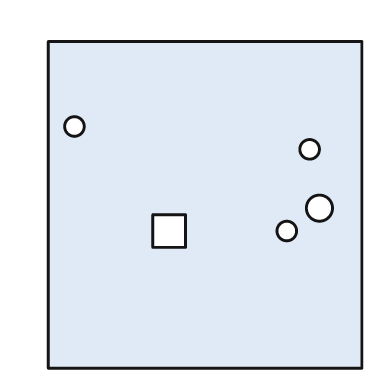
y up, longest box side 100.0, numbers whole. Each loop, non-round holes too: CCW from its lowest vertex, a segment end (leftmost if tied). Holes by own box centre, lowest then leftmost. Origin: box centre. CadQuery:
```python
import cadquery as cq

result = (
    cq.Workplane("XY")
    .moveTo(-48.0, -50.0)
    .lineTo(48.0, -50.0)
    .lineTo(48.0, 50.0)
    .lineTo(-48.0, 50.0)
    .close()
    .moveTo(-16.0, -13.0)
    .lineTo(-6.0, -13.0)
    .lineTo(-6.0, -3.0)
    .lineTo(-16.0, -3.0)
    .close()
    .moveTo(25.0, -8.0)
    .circle(3.0)
    .moveTo(35.0, -1.0)
    .circle(4.0)
    .moveTo(32.0, 17.0)
    .circle(3.0)
    .moveTo(-40.0, 24.0)
    .circle(3.0)
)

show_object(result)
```